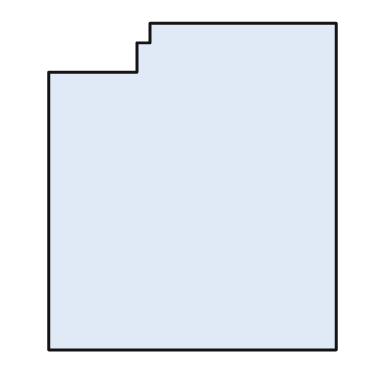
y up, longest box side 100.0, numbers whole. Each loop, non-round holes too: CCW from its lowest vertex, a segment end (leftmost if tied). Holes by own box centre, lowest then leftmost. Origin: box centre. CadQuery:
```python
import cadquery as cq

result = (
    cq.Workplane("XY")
    .moveTo(-44.0, -50.0)
    .lineTo(44.0, -50.0)
    .lineTo(44.0, 50.0)
    .lineTo(-13.0, 50.0)
    .lineTo(-13.0, 44.0)
    .lineTo(-17.0, 44.0)
    .lineTo(-17.0, 35.0)
    .lineTo(-44.0, 35.0)
    .close()
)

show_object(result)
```